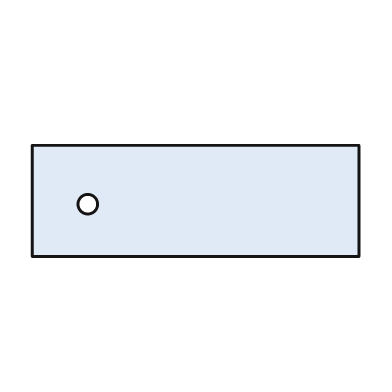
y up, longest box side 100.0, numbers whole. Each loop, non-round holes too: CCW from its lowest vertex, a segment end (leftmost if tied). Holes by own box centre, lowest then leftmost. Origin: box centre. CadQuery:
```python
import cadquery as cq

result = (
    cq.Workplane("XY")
    .moveTo(-50.0, -17.0)
    .lineTo(50.0, -17.0)
    .lineTo(50.0, 17.0)
    .lineTo(-50.0, 17.0)
    .close()
    .moveTo(-33.0, -1.0)
    .circle(3.0)
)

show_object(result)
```